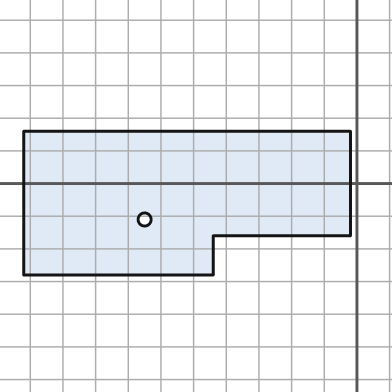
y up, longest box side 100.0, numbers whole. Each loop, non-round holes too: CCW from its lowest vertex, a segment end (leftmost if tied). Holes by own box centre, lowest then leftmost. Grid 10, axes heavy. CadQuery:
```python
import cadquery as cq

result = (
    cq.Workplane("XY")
    .moveTo(-102.0, -28.0)
    .lineTo(-44.0, -28.0)
    .lineTo(-44.0, -16.0)
    .lineTo(-2.0, -16.0)
    .lineTo(-2.0, 16.0)
    .lineTo(-102.0, 16.0)
    .close()
    .moveTo(-65.0, -11.0)
    .circle(2.0)
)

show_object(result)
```